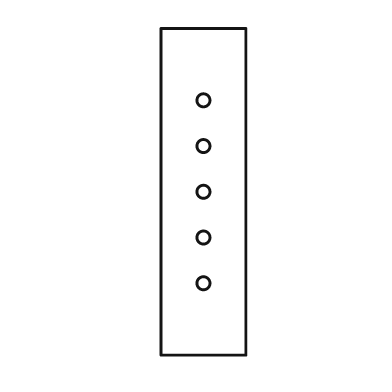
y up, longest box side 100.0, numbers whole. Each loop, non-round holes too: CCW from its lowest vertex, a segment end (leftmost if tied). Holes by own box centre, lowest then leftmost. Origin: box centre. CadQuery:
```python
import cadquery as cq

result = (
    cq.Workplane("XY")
    .moveTo(-13.0, -50.0)
    .lineTo(13.0, -50.0)
    .lineTo(13.0, 50.0)
    .lineTo(-13.0, 50.0)
    .close()
    .moveTo(0.0, -28.0)
    .circle(2.0)
    .moveTo(0.0, -14.0)
    .circle(2.0)
    .moveTo(0.0, 0.0)
    .circle(2.0)
    .moveTo(0.0, 14.0)
    .circle(2.0)
    .moveTo(0.0, 28.0)
    .circle(2.0)
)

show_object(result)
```